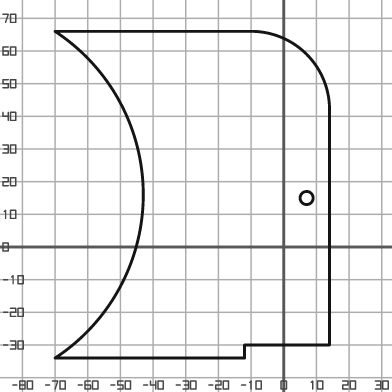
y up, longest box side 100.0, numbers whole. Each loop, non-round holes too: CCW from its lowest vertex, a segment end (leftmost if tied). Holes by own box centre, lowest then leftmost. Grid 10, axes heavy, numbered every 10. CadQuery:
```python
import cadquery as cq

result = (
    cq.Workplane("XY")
    .moveTo(-70.0, -34.0)
    .lineTo(-12.0, -34.0)
    .lineTo(-12.0, -30.0)
    .lineTo(14.0, -30.0)
    .lineTo(14.0, 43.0)
    .threePointArc((7.0, 59.0), (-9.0, 66.0))
    .lineTo(-70.0, 66.0)
    .threePointArc((-43.0, 16.0), (-70.0, -34.0))
    .close()
    .moveTo(7.0, 15.0)
    .circle(2.0)
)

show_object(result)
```